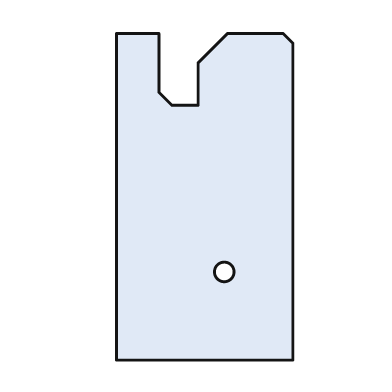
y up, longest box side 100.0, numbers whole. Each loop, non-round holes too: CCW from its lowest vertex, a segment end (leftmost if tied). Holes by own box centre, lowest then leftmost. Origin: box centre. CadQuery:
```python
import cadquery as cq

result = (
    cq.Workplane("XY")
    .moveTo(-27.0, -50.0)
    .lineTo(27.0, -50.0)
    .lineTo(27.0, 47.0)
    .lineTo(24.0, 50.0)
    .lineTo(7.0, 50.0)
    .lineTo(-2.0, 41.0)
    .lineTo(-2.0, 28.0)
    .lineTo(-10.0, 28.0)
    .lineTo(-14.0, 32.0)
    .lineTo(-14.0, 50.0)
    .lineTo(-27.0, 50.0)
    .close()
    .moveTo(6.0, -23.0)
    .circle(3.0)
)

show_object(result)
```